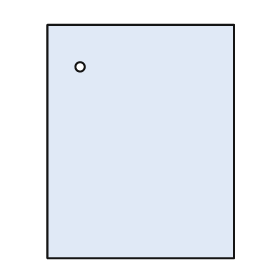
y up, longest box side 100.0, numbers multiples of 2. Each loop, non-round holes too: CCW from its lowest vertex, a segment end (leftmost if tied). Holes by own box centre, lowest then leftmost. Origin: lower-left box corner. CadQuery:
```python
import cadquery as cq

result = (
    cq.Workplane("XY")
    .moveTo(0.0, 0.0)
    .lineTo(80.0, 0.0)
    .lineTo(80.0, 100.0)
    .lineTo(0.0, 100.0)
    .close()
    .moveTo(14.0, 82.0)
    .circle(2.0)
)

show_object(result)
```